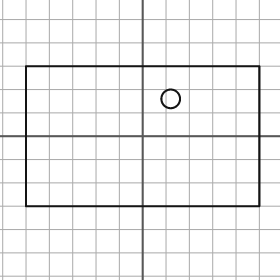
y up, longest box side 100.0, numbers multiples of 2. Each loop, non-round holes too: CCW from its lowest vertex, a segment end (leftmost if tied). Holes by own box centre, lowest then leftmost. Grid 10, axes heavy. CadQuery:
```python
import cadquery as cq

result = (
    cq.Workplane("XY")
    .moveTo(-50.0, -30.0)
    .lineTo(50.0, -30.0)
    .lineTo(50.0, 30.0)
    .lineTo(-50.0, 30.0)
    .close()
    .moveTo(12.0, 16.0)
    .circle(4.0)
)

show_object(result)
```